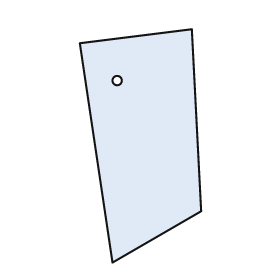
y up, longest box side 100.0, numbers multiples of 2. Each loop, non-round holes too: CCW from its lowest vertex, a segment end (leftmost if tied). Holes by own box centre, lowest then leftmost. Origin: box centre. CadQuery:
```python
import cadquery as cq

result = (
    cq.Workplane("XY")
    .moveTo(-12.0, -50.0)
    .lineTo(26.0, -28.0)
    .lineTo(22.0, 50.0)
    .lineTo(-26.0, 44.0)
    .close()
    .moveTo(-10.0, 28.0)
    .circle(2.0)
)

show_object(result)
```